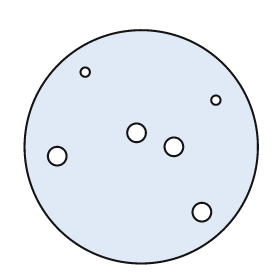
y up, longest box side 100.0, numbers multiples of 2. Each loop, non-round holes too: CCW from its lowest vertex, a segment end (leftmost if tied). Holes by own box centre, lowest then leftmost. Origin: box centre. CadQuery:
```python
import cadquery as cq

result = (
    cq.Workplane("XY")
    .moveTo(0.0, 0.0)
    .circle(50.0)
    .moveTo(26.0, -28.0)
    .circle(4.0)
    .moveTo(-36.0, -4.0)
    .circle(4.0)
    .moveTo(14.0, 0.0)
    .circle(4.0)
    .moveTo(-2.0, 6.0)
    .circle(4.0)
    .moveTo(32.0, 20.0)
    .circle(2.0)
    .moveTo(-24.0, 32.0)
    .circle(2.0)
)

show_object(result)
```